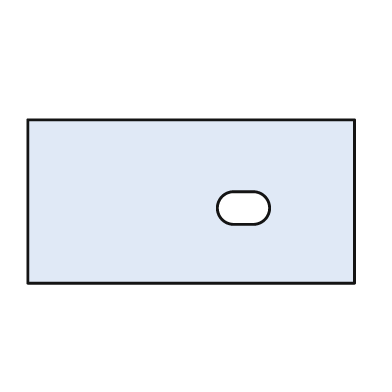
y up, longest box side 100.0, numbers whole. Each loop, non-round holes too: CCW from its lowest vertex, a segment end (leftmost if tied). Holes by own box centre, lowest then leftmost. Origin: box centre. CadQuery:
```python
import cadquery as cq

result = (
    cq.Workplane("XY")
    .moveTo(-50.0, -25.0)
    .lineTo(50.0, -25.0)
    .lineTo(50.0, 25.0)
    .lineTo(-50.0, 25.0)
    .close()
    .moveTo(13.0, -7.0)
    .lineTo(19.0, -7.0)
    .threePointArc((24.0, -2.0), (19.0, 3.0))
    .lineTo(13.0, 3.0)
    .threePointArc((8.0, -2.0), (13.0, -7.0))
    .close()
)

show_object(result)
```